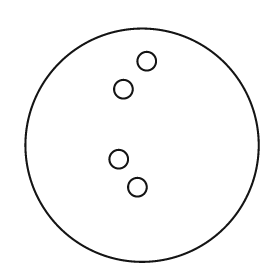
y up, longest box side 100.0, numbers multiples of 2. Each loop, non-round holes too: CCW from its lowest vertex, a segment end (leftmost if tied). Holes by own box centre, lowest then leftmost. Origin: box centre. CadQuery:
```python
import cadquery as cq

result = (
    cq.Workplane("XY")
    .moveTo(0.0, 0.0)
    .circle(50.0)
    .moveTo(-2.0, -18.0)
    .circle(4.0)
    .moveTo(-10.0, -6.0)
    .circle(4.0)
    .moveTo(-8.0, 24.0)
    .circle(4.0)
    .moveTo(2.0, 36.0)
    .circle(4.0)
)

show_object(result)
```